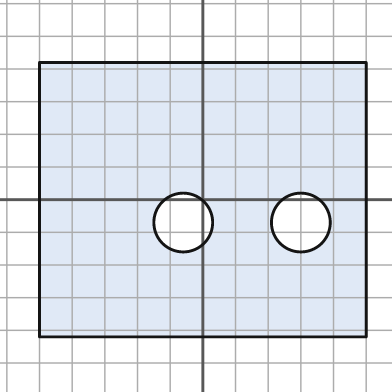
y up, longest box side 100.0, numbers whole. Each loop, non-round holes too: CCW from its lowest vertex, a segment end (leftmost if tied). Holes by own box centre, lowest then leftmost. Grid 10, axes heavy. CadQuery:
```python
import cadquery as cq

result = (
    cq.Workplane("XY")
    .moveTo(-50.0, -42.0)
    .lineTo(50.0, -42.0)
    .lineTo(50.0, 42.0)
    .lineTo(-50.0, 42.0)
    .close()
    .moveTo(-6.0, -7.0)
    .circle(9.0)
    .moveTo(30.0, -7.0)
    .circle(9.0)
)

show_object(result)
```